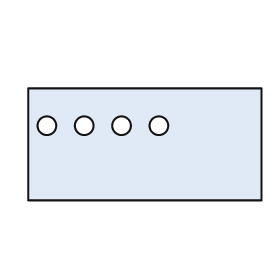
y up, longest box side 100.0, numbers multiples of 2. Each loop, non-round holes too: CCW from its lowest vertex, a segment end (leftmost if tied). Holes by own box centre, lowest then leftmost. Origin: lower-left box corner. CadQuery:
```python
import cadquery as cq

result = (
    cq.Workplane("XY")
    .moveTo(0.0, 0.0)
    .lineTo(100.0, 0.0)
    .lineTo(100.0, 48.0)
    .lineTo(0.0, 48.0)
    .close()
    .moveTo(8.0, 32.0)
    .circle(4.0)
    .moveTo(24.0, 32.0)
    .circle(4.0)
    .moveTo(40.0, 32.0)
    .circle(4.0)
    .moveTo(56.0, 32.0)
    .circle(4.0)
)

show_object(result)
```